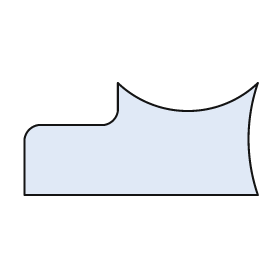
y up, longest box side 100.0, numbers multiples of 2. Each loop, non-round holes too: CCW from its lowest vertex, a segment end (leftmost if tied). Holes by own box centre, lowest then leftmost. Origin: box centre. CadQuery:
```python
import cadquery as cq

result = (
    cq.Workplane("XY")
    .moveTo(-50.0, -24.0)
    .lineTo(50.0, -24.0)
    .threePointArc((46.0, 0.0), (50.0, 24.0))
    .threePointArc((20.0, 12.0), (-10.0, 24.0))
    .lineTo(-10.0, 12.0)
    .threePointArc((-12.0, 8.0), (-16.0, 6.0))
    .lineTo(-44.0, 6.0)
    .threePointArc((-48.0, 4.0), (-50.0, 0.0))
    .close()
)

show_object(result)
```